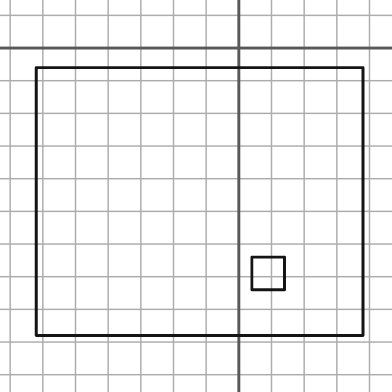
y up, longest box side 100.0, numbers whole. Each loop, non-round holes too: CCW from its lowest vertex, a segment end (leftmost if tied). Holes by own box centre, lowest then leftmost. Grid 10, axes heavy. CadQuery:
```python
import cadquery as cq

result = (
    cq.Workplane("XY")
    .moveTo(-62.0, -88.0)
    .lineTo(38.0, -88.0)
    .lineTo(38.0, -6.0)
    .lineTo(-62.0, -6.0)
    .close()
    .moveTo(4.0, -74.0)
    .lineTo(14.0, -74.0)
    .lineTo(14.0, -64.0)
    .lineTo(4.0, -64.0)
    .close()
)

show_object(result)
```